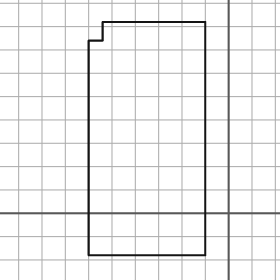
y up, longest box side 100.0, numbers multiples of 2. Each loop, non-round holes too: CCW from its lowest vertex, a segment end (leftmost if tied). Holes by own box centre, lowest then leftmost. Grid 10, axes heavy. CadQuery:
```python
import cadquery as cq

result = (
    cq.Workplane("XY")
    .moveTo(-60.0, -18.0)
    .lineTo(-10.0, -18.0)
    .lineTo(-10.0, 82.0)
    .lineTo(-54.0, 82.0)
    .lineTo(-54.0, 74.0)
    .lineTo(-60.0, 74.0)
    .close()
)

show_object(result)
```